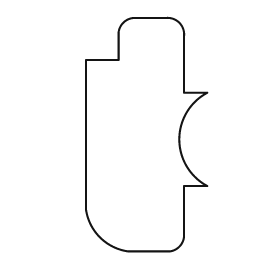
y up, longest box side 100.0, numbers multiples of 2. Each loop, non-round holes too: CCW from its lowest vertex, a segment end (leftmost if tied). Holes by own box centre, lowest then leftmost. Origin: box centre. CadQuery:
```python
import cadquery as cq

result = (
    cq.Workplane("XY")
    .moveTo(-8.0, -50.0)
    .lineTo(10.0, -50.0)
    .threePointArc((14.0, -48.0), (16.0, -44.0))
    .lineTo(16.0, -22.0)
    .lineTo(26.0, -22.0)
    .threePointArc((14.0, -2.0), (26.0, 18.0))
    .lineTo(16.0, 18.0)
    .lineTo(16.0, 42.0)
    .threePointArc((14.0, 48.0), (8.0, 50.0))
    .lineTo(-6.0, 50.0)
    .threePointArc((-10.0, 48.0), (-12.0, 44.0))
    .lineTo(-12.0, 32.0)
    .lineTo(-26.0, 32.0)
    .lineTo(-26.0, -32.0)
    .threePointArc((-20.0, -44.0), (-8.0, -50.0))
    .close()
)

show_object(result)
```